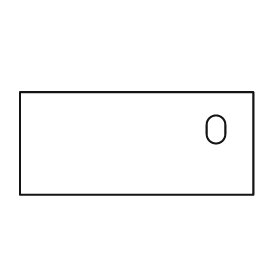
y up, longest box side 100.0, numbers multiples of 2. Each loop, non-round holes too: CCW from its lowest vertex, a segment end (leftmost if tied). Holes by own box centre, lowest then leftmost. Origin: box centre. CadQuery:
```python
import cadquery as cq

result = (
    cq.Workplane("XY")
    .moveTo(-50.0, -22.0)
    .lineTo(50.0, -22.0)
    .lineTo(50.0, 22.0)
    .lineTo(-50.0, 22.0)
    .close()
    .moveTo(30.0, 4.0)
    .threePointArc((34.0, 0.0), (38.0, 4.0))
    .lineTo(38.0, 8.0)
    .threePointArc((34.0, 12.0), (30.0, 8.0))
    .close()
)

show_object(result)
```